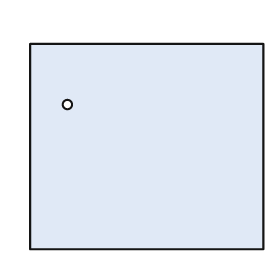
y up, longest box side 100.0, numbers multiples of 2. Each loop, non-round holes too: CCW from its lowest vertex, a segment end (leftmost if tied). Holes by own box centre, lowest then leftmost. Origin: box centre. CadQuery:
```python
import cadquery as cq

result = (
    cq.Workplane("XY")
    .moveTo(-50.0, -44.0)
    .lineTo(50.0, -44.0)
    .lineTo(50.0, 44.0)
    .lineTo(-50.0, 44.0)
    .close()
    .moveTo(-34.0, 18.0)
    .circle(2.0)
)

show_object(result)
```